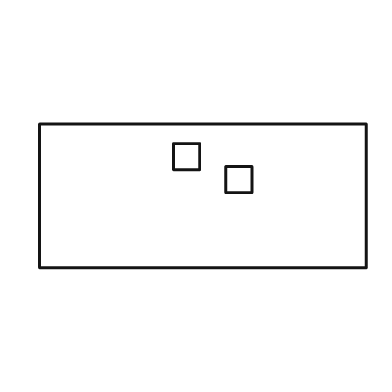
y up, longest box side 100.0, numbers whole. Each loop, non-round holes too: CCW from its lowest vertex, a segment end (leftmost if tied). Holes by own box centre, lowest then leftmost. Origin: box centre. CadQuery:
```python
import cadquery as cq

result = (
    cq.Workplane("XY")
    .moveTo(-50.0, -22.0)
    .lineTo(50.0, -22.0)
    .lineTo(50.0, 22.0)
    .lineTo(-50.0, 22.0)
    .close()
    .moveTo(7.0, 1.0)
    .lineTo(15.0, 1.0)
    .lineTo(15.0, 9.0)
    .lineTo(7.0, 9.0)
    .close()
    .moveTo(-9.0, 8.0)
    .lineTo(-1.0, 8.0)
    .lineTo(-1.0, 16.0)
    .lineTo(-9.0, 16.0)
    .close()
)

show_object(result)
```